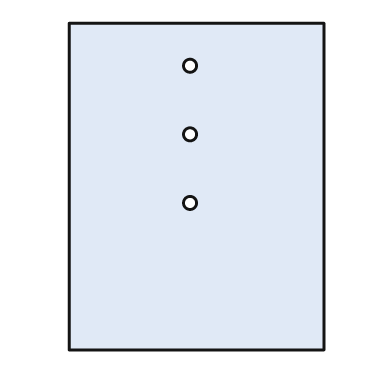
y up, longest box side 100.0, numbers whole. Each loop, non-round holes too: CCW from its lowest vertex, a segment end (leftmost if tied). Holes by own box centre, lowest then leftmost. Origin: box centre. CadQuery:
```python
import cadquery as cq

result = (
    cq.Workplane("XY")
    .moveTo(-39.0, -50.0)
    .lineTo(39.0, -50.0)
    .lineTo(39.0, 50.0)
    .lineTo(-39.0, 50.0)
    .close()
    .moveTo(-2.0, -5.0)
    .circle(2.0)
    .moveTo(-2.0, 16.0)
    .circle(2.0)
    .moveTo(-2.0, 37.0)
    .circle(2.0)
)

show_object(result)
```